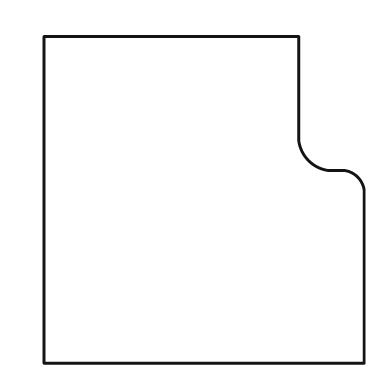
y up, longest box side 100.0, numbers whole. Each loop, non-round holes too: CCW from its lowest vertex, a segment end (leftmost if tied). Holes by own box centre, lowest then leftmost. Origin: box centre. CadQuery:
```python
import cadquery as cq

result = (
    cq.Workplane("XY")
    .moveTo(-49.0, -50.0)
    .lineTo(49.0, -50.0)
    .lineTo(49.0, 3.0)
    .threePointArc((47.0, 7.0), (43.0, 9.0))
    .lineTo(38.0, 9.0)
    .threePointArc((32.0, 12.0), (29.0, 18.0))
    .lineTo(29.0, 50.0)
    .lineTo(-49.0, 50.0)
    .close()
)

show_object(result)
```